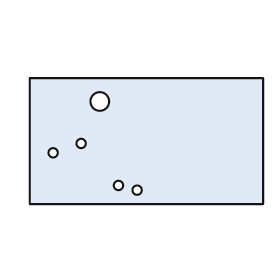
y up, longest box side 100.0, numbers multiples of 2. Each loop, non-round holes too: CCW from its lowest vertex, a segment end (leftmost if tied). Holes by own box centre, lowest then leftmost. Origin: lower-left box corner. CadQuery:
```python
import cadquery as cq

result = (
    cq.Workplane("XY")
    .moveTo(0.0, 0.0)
    .lineTo(100.0, 0.0)
    .lineTo(100.0, 54.0)
    .lineTo(0.0, 54.0)
    .close()
    .moveTo(46.0, 6.0)
    .circle(2.0)
    .moveTo(38.0, 8.0)
    .circle(2.0)
    .moveTo(10.0, 22.0)
    .circle(2.0)
    .moveTo(22.0, 26.0)
    .circle(2.0)
    .moveTo(30.0, 44.0)
    .circle(4.0)
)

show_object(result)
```